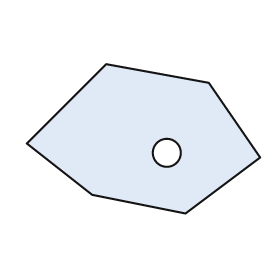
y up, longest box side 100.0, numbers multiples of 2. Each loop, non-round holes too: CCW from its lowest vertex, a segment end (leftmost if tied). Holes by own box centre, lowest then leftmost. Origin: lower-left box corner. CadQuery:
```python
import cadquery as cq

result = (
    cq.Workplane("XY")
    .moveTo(68.0, 0.0)
    .lineTo(100.0, 24.0)
    .lineTo(78.0, 56.0)
    .lineTo(34.0, 64.0)
    .lineTo(0.0, 30.0)
    .lineTo(28.0, 8.0)
    .close()
    .moveTo(60.0, 26.0)
    .circle(6.0)
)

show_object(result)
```